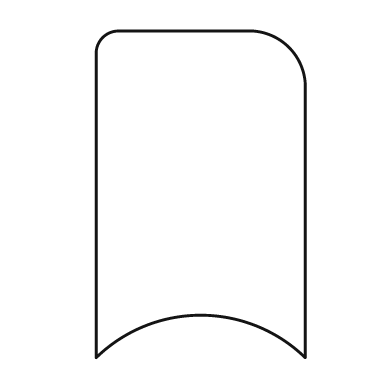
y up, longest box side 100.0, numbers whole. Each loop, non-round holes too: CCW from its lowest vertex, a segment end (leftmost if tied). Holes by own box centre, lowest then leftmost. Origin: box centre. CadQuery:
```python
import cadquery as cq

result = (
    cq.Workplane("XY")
    .moveTo(-32.0, -50.0)
    .threePointArc((0.0, -37.0), (32.0, -50.0))
    .lineTo(32.0, 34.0)
    .threePointArc((27.0, 45.0), (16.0, 50.0))
    .lineTo(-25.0, 50.0)
    .threePointArc((-30.0, 48.0), (-32.0, 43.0))
    .close()
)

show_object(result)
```